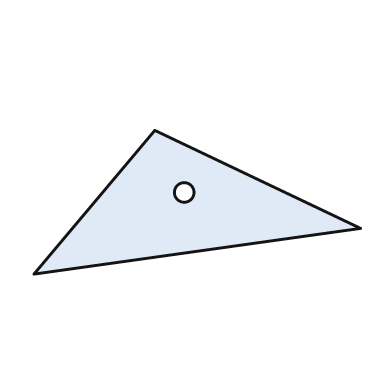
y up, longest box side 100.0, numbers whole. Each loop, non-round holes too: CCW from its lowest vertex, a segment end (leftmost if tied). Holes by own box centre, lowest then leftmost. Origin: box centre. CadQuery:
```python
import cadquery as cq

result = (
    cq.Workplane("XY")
    .moveTo(-50.0, -22.0)
    .lineTo(50.0, -8.0)
    .lineTo(-13.0, 22.0)
    .close()
    .moveTo(-4.0, 3.0)
    .circle(3.0)
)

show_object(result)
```